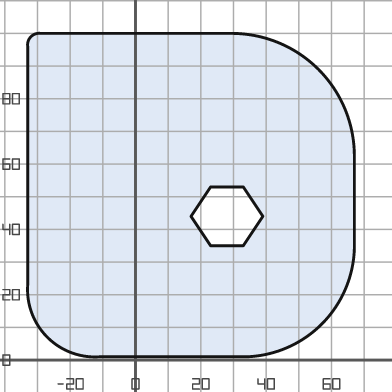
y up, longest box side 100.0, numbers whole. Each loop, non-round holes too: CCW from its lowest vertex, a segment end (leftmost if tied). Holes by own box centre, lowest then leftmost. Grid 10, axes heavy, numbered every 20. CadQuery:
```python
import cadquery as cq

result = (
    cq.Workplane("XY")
    .moveTo(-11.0, 1.0)
    .lineTo(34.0, 1.0)
    .threePointArc((57.0, 11.0), (67.0, 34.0))
    .lineTo(67.0, 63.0)
    .threePointArc((56.0, 89.0), (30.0, 100.0))
    .lineTo(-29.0, 100.0)
    .threePointArc((-32.0, 99.0), (-33.0, 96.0))
    .lineTo(-33.0, 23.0)
    .threePointArc((-27.0, 7.0), (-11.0, 1.0))
    .close()
    .moveTo(23.0, 35.0)
    .lineTo(33.0, 35.0)
    .lineTo(39.0, 44.0)
    .lineTo(33.0, 53.0)
    .lineTo(23.0, 53.0)
    .lineTo(17.0, 44.0)
    .close()
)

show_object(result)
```